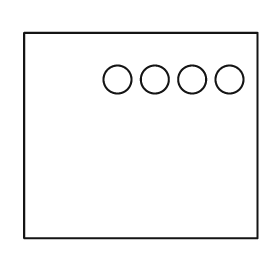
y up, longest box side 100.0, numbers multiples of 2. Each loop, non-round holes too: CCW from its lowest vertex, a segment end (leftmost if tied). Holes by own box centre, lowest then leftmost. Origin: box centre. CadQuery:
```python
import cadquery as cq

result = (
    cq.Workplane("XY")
    .moveTo(-50.0, -44.0)
    .lineTo(50.0, -44.0)
    .lineTo(50.0, 44.0)
    .lineTo(-50.0, 44.0)
    .close()
    .moveTo(-10.0, 24.0)
    .circle(6.0)
    .moveTo(6.0, 24.0)
    .circle(6.0)
    .moveTo(22.0, 24.0)
    .circle(6.0)
    .moveTo(38.0, 24.0)
    .circle(6.0)
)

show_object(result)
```